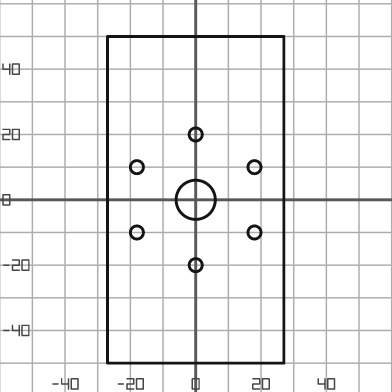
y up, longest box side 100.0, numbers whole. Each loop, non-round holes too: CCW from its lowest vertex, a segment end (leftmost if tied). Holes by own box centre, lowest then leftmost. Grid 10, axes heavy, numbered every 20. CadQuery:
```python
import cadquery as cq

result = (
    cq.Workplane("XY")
    .moveTo(-27.0, -50.0)
    .lineTo(27.0, -50.0)
    .lineTo(27.0, 50.0)
    .lineTo(-27.0, 50.0)
    .close()
    .moveTo(0.0, -20.0)
    .circle(2.0)
    .moveTo(-18.0, -10.0)
    .circle(2.0)
    .moveTo(18.0, -10.0)
    .circle(2.0)
    .moveTo(0.0, 0.0)
    .circle(6.0)
    .moveTo(-18.0, 10.0)
    .circle(2.0)
    .moveTo(18.0, 10.0)
    .circle(2.0)
    .moveTo(0.0, 20.0)
    .circle(2.0)
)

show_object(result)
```